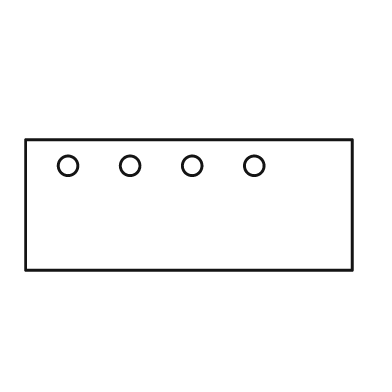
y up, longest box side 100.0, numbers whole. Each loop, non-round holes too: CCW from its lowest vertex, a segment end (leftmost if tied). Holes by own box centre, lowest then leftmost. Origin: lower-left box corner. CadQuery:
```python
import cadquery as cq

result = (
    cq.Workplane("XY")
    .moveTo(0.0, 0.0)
    .lineTo(100.0, 0.0)
    .lineTo(100.0, 40.0)
    .lineTo(0.0, 40.0)
    .close()
    .moveTo(13.0, 32.0)
    .circle(3.0)
    .moveTo(32.0, 32.0)
    .circle(3.0)
    .moveTo(51.0, 32.0)
    .circle(3.0)
    .moveTo(70.0, 32.0)
    .circle(3.0)
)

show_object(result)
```